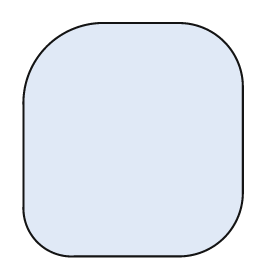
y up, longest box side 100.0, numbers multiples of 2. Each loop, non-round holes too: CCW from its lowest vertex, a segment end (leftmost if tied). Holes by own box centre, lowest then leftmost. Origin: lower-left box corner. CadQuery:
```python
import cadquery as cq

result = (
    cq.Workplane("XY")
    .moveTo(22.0, 0.0)
    .lineTo(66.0, 0.0)
    .threePointArc((86.0, 8.0), (94.0, 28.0))
    .lineTo(94.0, 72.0)
    .threePointArc((86.0, 92.0), (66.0, 100.0))
    .lineTo(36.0, 100.0)
    .threePointArc((10.0, 90.0), (0.0, 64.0))
    .lineTo(0.0, 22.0)
    .threePointArc((6.0, 6.0), (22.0, 0.0))
    .close()
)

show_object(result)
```